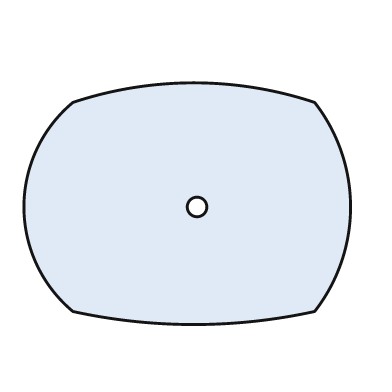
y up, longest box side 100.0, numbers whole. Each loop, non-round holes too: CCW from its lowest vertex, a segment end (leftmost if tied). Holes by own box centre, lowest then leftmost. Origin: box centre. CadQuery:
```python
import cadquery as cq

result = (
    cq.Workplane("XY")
    .moveTo(-35.0, -33.0)
    .threePointArc((2.0, -37.0), (39.0, -33.0))
    .threePointArc((50.0, -1.0), (39.0, 31.0))
    .threePointArc((2.0, 37.0), (-35.0, 31.0))
    .threePointArc((-50.0, -1.0), (-35.0, -33.0))
    .close()
    .moveTo(3.0, -1.0)
    .circle(3.0)
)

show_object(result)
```